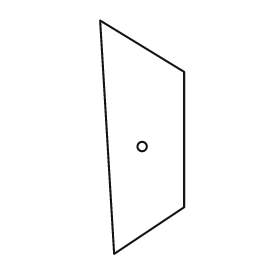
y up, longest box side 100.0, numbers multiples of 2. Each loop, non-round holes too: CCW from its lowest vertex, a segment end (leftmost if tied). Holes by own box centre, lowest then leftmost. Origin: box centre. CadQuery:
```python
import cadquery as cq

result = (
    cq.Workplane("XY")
    .moveTo(-12.0, -50.0)
    .lineTo(18.0, -30.0)
    .lineTo(18.0, 28.0)
    .lineTo(-18.0, 50.0)
    .close()
    .moveTo(0.0, -4.0)
    .circle(2.0)
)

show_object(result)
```